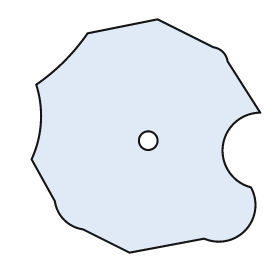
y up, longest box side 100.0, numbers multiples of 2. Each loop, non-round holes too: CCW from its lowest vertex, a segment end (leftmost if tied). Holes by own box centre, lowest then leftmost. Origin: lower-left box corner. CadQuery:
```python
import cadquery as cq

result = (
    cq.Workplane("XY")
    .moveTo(42.0, 0.0)
    .lineTo(74.0, 6.0)
    .threePointArc((92.0, 10.0), (94.0, 28.0))
    .threePointArc((82.0, 46.0), (98.0, 60.0))
    .lineTo(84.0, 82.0)
    .threePointArc((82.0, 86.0), (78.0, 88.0))
    .lineTo(54.0, 100.0)
    .lineTo(24.0, 94.0)
    .threePointArc((14.0, 82.0), (2.0, 72.0))
    .threePointArc((4.0, 56.0), (0.0, 40.0))
    .lineTo(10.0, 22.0)
    .threePointArc((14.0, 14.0), (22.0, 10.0))
    .close()
    .moveTo(50.0, 48.0)
    .circle(4.0)
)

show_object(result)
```